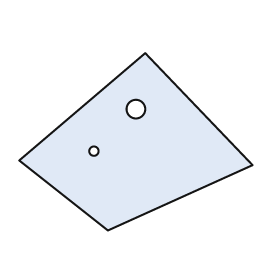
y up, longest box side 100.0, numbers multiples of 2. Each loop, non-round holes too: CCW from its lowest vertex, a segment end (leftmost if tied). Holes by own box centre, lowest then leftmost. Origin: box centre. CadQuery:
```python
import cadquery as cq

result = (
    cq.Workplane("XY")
    .moveTo(-12.0, -38.0)
    .lineTo(50.0, -10.0)
    .lineTo(4.0, 38.0)
    .lineTo(-50.0, -8.0)
    .close()
    .moveTo(-18.0, -4.0)
    .circle(2.0)
    .moveTo(0.0, 14.0)
    .circle(4.0)
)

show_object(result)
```